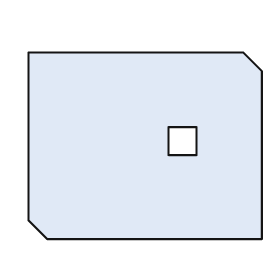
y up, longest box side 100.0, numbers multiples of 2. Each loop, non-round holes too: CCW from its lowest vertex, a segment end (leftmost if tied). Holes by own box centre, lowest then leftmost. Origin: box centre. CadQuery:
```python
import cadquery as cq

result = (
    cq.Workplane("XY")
    .moveTo(-42.0, -40.0)
    .lineTo(50.0, -40.0)
    .lineTo(50.0, 32.0)
    .lineTo(42.0, 40.0)
    .lineTo(-50.0, 40.0)
    .lineTo(-50.0, -32.0)
    .close()
    .moveTo(10.0, -4.0)
    .lineTo(22.0, -4.0)
    .lineTo(22.0, 8.0)
    .lineTo(10.0, 8.0)
    .close()
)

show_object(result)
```